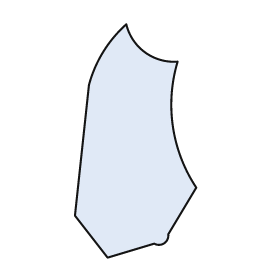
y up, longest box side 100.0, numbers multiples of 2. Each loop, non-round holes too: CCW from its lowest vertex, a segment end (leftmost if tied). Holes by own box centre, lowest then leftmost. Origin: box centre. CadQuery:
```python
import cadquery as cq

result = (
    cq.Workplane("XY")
    .moveTo(-12.0, -50.0)
    .lineTo(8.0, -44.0)
    .threePointArc((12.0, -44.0), (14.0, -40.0))
    .lineTo(26.0, -20.0)
    .threePointArc((16.0, 6.0), (18.0, 34.0))
    .threePointArc((4.0, 38.0), (-4.0, 50.0))
    .threePointArc((-14.0, 38.0), (-20.0, 24.0))
    .lineTo(-26.0, -32.0)
    .close()
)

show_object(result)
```